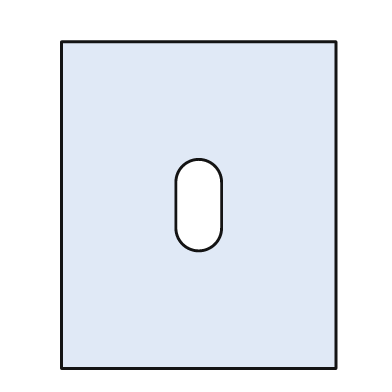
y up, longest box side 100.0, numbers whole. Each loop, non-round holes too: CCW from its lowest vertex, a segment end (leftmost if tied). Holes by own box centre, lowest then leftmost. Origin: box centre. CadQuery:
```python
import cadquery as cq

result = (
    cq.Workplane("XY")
    .moveTo(-42.0, -50.0)
    .lineTo(42.0, -50.0)
    .lineTo(42.0, 50.0)
    .lineTo(-42.0, 50.0)
    .close()
    .moveTo(-7.0, -7.0)
    .threePointArc((0.0, -14.0), (7.0, -7.0))
    .lineTo(7.0, 7.0)
    .threePointArc((0.0, 14.0), (-7.0, 7.0))
    .close()
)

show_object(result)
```